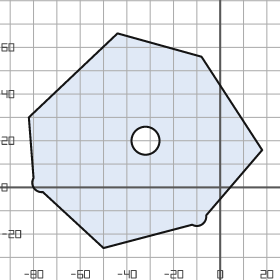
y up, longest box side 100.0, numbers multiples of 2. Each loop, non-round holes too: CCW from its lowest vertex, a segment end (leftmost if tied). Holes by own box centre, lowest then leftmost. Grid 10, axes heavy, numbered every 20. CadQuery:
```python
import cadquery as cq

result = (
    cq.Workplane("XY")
    .moveTo(-50.0, -26.0)
    .lineTo(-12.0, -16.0)
    .threePointArc((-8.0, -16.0), (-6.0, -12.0))
    .lineTo(18.0, 16.0)
    .lineTo(-8.0, 56.0)
    .lineTo(-44.0, 66.0)
    .lineTo(-82.0, 30.0)
    .lineTo(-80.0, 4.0)
    .threePointArc((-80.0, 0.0), (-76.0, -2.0))
    .close()
    .moveTo(-32.0, 20.0)
    .circle(6.0)
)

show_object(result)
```